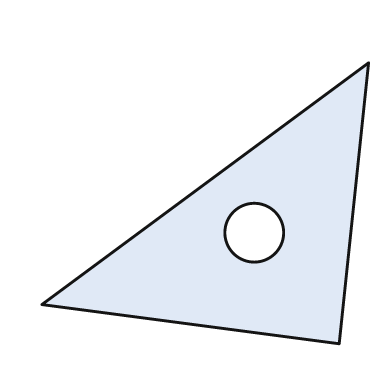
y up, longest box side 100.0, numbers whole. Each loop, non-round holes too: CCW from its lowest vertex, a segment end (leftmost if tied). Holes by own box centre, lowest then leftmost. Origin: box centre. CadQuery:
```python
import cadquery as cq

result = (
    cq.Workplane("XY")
    .moveTo(41.0, -43.0)
    .lineTo(50.0, 43.0)
    .lineTo(-50.0, -31.0)
    .close()
    .moveTo(15.0, -9.0)
    .circle(9.0)
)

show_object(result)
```